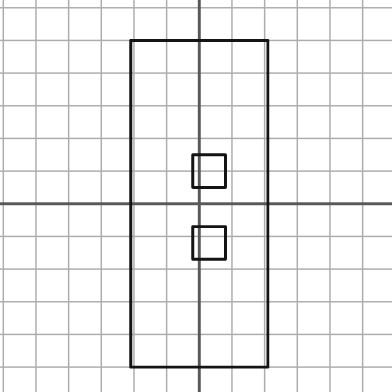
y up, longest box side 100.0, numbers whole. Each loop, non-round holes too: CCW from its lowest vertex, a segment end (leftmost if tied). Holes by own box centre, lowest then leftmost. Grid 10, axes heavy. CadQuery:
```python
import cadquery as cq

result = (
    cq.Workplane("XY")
    .moveTo(-21.0, -50.0)
    .lineTo(21.0, -50.0)
    .lineTo(21.0, 50.0)
    .lineTo(-21.0, 50.0)
    .close()
    .moveTo(-2.0, -17.0)
    .lineTo(8.0, -17.0)
    .lineTo(8.0, -7.0)
    .lineTo(-2.0, -7.0)
    .close()
    .moveTo(-2.0, 5.0)
    .lineTo(8.0, 5.0)
    .lineTo(8.0, 15.0)
    .lineTo(-2.0, 15.0)
    .close()
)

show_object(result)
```